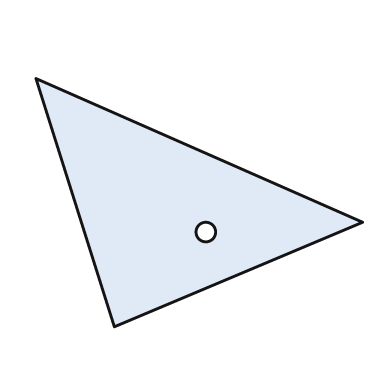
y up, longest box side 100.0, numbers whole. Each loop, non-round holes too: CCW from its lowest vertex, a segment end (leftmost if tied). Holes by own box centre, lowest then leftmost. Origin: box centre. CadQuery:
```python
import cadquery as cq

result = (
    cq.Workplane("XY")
    .moveTo(-26.0, -38.0)
    .lineTo(50.0, -6.0)
    .lineTo(-50.0, 38.0)
    .close()
    .moveTo(2.0, -9.0)
    .circle(3.0)
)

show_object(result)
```